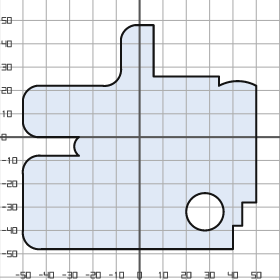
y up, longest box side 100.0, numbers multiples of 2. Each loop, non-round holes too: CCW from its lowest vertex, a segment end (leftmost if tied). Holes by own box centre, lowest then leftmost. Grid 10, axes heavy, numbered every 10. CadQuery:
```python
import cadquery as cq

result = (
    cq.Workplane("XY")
    .moveTo(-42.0, -48.0)
    .lineTo(40.0, -48.0)
    .lineTo(40.0, -38.0)
    .lineTo(44.0, -38.0)
    .lineTo(44.0, -28.0)
    .lineTo(50.0, -28.0)
    .lineTo(50.0, 22.0)
    .threePointArc((42.0, 24.0), (34.0, 22.0))
    .lineTo(34.0, 26.0)
    .lineTo(6.0, 26.0)
    .lineTo(6.0, 48.0)
    .lineTo(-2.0, 48.0)
    .threePointArc((-6.0, 46.0), (-8.0, 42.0))
    .lineTo(-8.0, 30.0)
    .threePointArc((-10.0, 24.0), (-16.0, 22.0))
    .lineTo(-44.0, 22.0)
    .threePointArc((-48.0, 20.0), (-50.0, 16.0))
    .lineTo(-50.0, 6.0)
    .threePointArc((-48.0, 2.0), (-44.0, 0.0))
    .lineTo(-26.0, 0.0)
    .threePointArc((-28.0, -4.0), (-26.0, -8.0))
    .lineTo(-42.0, -8.0)
    .threePointArc((-48.0, -10.0), (-50.0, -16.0))
    .lineTo(-50.0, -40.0)
    .threePointArc((-48.0, -46.0), (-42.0, -48.0))
    .close()
    .moveTo(28.0, -32.0)
    .circle(8.0)
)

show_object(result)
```